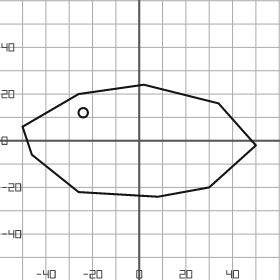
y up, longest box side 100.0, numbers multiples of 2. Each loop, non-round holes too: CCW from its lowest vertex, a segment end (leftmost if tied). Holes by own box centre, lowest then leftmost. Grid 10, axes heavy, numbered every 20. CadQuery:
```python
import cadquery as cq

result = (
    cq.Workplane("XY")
    .moveTo(8.0, -24.0)
    .lineTo(30.0, -20.0)
    .lineTo(50.0, -2.0)
    .lineTo(34.0, 16.0)
    .lineTo(2.0, 24.0)
    .lineTo(-26.0, 20.0)
    .lineTo(-50.0, 6.0)
    .lineTo(-46.0, -6.0)
    .lineTo(-26.0, -22.0)
    .close()
    .moveTo(-24.0, 12.0)
    .circle(2.0)
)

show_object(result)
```